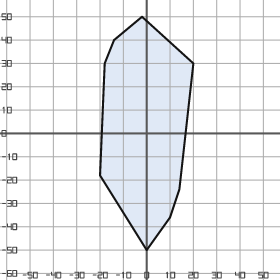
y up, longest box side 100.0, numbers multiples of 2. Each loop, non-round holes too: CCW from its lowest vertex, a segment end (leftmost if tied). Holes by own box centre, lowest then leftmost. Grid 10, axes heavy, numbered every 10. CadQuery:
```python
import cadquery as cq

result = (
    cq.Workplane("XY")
    .moveTo(0.0, -50.0)
    .lineTo(10.0, -36.0)
    .lineTo(14.0, -24.0)
    .lineTo(20.0, 30.0)
    .lineTo(-2.0, 50.0)
    .lineTo(-14.0, 40.0)
    .lineTo(-18.0, 30.0)
    .lineTo(-20.0, -18.0)
    .close()
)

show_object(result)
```